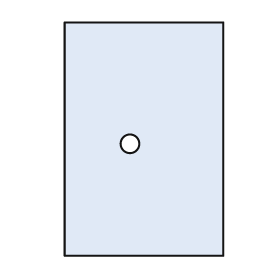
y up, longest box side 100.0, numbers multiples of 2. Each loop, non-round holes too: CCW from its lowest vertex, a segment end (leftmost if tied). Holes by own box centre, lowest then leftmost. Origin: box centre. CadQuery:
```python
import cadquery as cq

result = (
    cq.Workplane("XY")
    .moveTo(-34.0, -50.0)
    .lineTo(34.0, -50.0)
    .lineTo(34.0, 50.0)
    .lineTo(-34.0, 50.0)
    .close()
    .moveTo(-6.0, -2.0)
    .circle(4.0)
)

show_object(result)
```